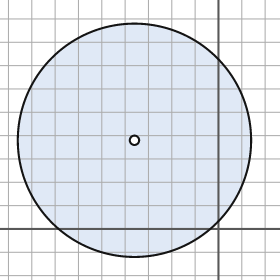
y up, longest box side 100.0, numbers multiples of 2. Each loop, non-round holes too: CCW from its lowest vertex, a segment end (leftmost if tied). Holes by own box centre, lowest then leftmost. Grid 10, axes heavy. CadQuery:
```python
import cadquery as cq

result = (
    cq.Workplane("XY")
    .moveTo(-36.0, 38.0)
    .circle(50.0)
    .moveTo(-36.0, 38.0)
    .circle(2.0)
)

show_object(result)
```